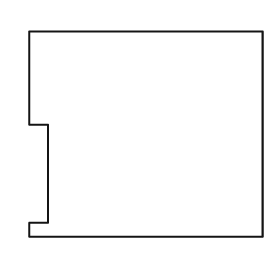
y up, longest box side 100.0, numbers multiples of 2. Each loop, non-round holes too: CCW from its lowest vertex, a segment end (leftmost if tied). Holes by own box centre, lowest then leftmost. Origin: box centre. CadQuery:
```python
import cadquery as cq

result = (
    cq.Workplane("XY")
    .moveTo(-50.0, -44.0)
    .lineTo(50.0, -44.0)
    .lineTo(50.0, 44.0)
    .lineTo(-50.0, 44.0)
    .lineTo(-50.0, 4.0)
    .lineTo(-42.0, 4.0)
    .lineTo(-42.0, -38.0)
    .lineTo(-50.0, -38.0)
    .close()
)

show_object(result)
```